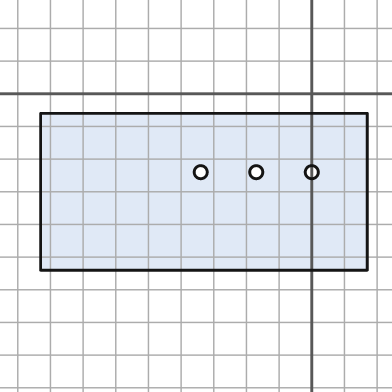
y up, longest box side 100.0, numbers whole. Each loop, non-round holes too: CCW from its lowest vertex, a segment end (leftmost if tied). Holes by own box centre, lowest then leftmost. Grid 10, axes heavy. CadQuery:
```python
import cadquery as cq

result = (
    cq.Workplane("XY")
    .moveTo(-83.0, -54.0)
    .lineTo(17.0, -54.0)
    .lineTo(17.0, -6.0)
    .lineTo(-83.0, -6.0)
    .close()
    .moveTo(-34.0, -24.0)
    .circle(2.0)
    .moveTo(-17.0, -24.0)
    .circle(2.0)
    .moveTo(0.0, -24.0)
    .circle(2.0)
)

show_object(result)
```